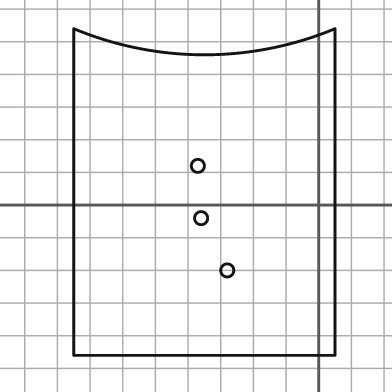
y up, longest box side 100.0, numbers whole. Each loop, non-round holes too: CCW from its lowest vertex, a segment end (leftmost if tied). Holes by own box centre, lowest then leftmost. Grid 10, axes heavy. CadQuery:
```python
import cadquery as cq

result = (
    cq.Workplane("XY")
    .moveTo(-75.0, -46.0)
    .lineTo(5.0, -46.0)
    .lineTo(5.0, 54.0)
    .threePointArc((-35.0, 46.0), (-75.0, 54.0))
    .close()
    .moveTo(-28.0, -20.0)
    .circle(2.0)
    .moveTo(-36.0, -4.0)
    .circle(2.0)
    .moveTo(-37.0, 12.0)
    .circle(2.0)
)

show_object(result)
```